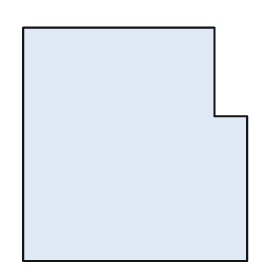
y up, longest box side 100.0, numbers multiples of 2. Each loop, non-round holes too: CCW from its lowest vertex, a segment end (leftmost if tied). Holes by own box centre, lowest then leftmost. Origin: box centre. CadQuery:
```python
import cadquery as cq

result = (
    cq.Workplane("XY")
    .moveTo(-48.0, -50.0)
    .lineTo(48.0, -50.0)
    .lineTo(48.0, 12.0)
    .lineTo(34.0, 12.0)
    .lineTo(34.0, 50.0)
    .lineTo(-48.0, 50.0)
    .close()
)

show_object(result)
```